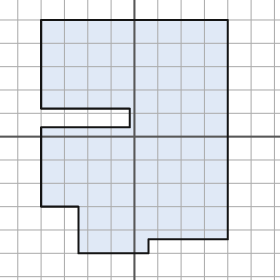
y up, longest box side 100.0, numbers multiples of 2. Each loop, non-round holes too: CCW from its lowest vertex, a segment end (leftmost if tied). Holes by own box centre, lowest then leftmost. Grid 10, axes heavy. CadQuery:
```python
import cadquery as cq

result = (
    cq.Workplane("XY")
    .moveTo(-24.0, -50.0)
    .lineTo(6.0, -50.0)
    .lineTo(6.0, -44.0)
    .lineTo(40.0, -44.0)
    .lineTo(40.0, 50.0)
    .lineTo(-40.0, 50.0)
    .lineTo(-40.0, 12.0)
    .lineTo(-2.0, 12.0)
    .lineTo(-2.0, 4.0)
    .lineTo(-40.0, 4.0)
    .lineTo(-40.0, -30.0)
    .lineTo(-24.0, -30.0)
    .close()
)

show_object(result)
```